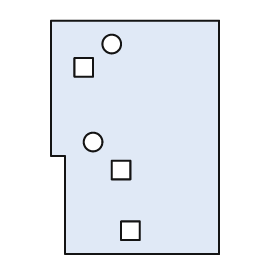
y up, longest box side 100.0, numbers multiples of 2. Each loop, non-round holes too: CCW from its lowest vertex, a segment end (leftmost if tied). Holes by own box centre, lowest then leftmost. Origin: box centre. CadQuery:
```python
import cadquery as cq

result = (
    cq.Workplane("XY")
    .moveTo(-30.0, -50.0)
    .lineTo(36.0, -50.0)
    .lineTo(36.0, 50.0)
    .lineTo(-36.0, 50.0)
    .lineTo(-36.0, -8.0)
    .lineTo(-30.0, -8.0)
    .close()
    .moveTo(-6.0, -44.0)
    .lineTo(2.0, -44.0)
    .lineTo(2.0, -36.0)
    .lineTo(-6.0, -36.0)
    .close()
    .moveTo(-10.0, -18.0)
    .lineTo(-2.0, -18.0)
    .lineTo(-2.0, -10.0)
    .lineTo(-10.0, -10.0)
    .close()
    .moveTo(-18.0, -2.0)
    .circle(4.0)
    .moveTo(-26.0, 26.0)
    .lineTo(-18.0, 26.0)
    .lineTo(-18.0, 34.0)
    .lineTo(-26.0, 34.0)
    .close()
    .moveTo(-10.0, 40.0)
    .circle(4.0)
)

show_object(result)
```